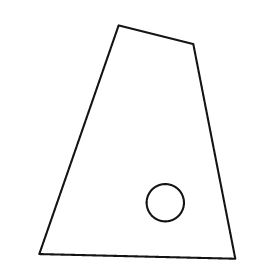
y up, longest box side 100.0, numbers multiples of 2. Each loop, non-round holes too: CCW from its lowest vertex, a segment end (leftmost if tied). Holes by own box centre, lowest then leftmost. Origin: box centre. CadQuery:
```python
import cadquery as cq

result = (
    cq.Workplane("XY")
    .moveTo(42.0, -50.0)
    .lineTo(24.0, 42.0)
    .lineTo(-8.0, 50.0)
    .lineTo(-42.0, -48.0)
    .close()
    .moveTo(12.0, -26.0)
    .circle(8.0)
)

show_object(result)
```